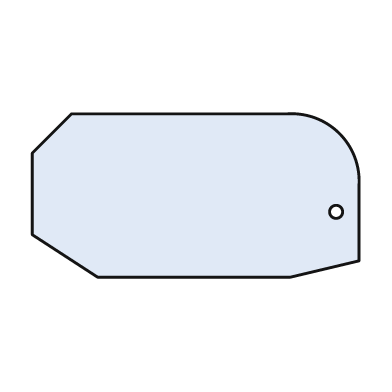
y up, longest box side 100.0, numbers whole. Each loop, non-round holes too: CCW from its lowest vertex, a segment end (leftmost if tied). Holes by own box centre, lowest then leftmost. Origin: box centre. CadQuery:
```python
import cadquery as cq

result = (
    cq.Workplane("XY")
    .moveTo(-30.0, -25.0)
    .lineTo(29.0, -25.0)
    .lineTo(50.0, -20.0)
    .lineTo(50.0, 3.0)
    .threePointArc((44.0, 19.0), (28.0, 25.0))
    .lineTo(-38.0, 25.0)
    .lineTo(-50.0, 13.0)
    .lineTo(-50.0, -12.0)
    .close()
    .moveTo(43.0, -5.0)
    .circle(2.0)
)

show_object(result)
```